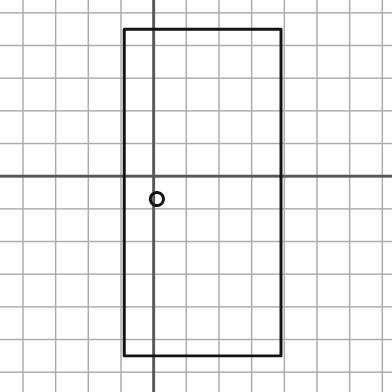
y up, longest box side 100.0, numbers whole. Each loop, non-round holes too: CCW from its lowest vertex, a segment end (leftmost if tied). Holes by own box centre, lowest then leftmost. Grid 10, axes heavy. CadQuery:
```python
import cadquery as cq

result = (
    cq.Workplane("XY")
    .moveTo(-9.0, -55.0)
    .lineTo(39.0, -55.0)
    .lineTo(39.0, 45.0)
    .lineTo(-9.0, 45.0)
    .close()
    .moveTo(1.0, -7.0)
    .circle(2.0)
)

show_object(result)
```